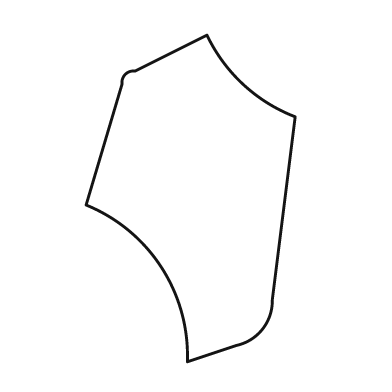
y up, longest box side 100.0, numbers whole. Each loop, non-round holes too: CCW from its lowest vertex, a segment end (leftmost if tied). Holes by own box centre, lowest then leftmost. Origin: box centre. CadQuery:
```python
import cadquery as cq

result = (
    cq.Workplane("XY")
    .moveTo(-1.0, -50.0)
    .lineTo(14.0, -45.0)
    .threePointArc((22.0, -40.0), (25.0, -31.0))
    .lineTo(32.0, 25.0)
    .threePointArc((16.0, 35.0), (5.0, 50.0))
    .lineTo(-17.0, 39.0)
    .threePointArc((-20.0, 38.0), (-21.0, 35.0))
    .lineTo(-32.0, -2.0)
    .threePointArc((-9.0, -21.0), (-1.0, -50.0))
    .close()
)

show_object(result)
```